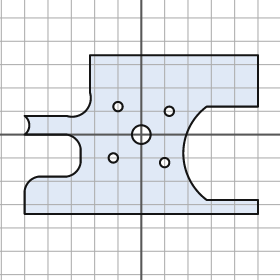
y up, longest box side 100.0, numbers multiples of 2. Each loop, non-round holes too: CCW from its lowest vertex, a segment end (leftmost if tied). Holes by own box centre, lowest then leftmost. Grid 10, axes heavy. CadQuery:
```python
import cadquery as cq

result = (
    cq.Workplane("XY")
    .moveTo(-50.0, -34.0)
    .lineTo(50.0, -34.0)
    .lineTo(50.0, -28.0)
    .lineTo(28.0, -28.0)
    .threePointArc((18.0, -8.0), (28.0, 12.0))
    .lineTo(50.0, 12.0)
    .lineTo(50.0, 34.0)
    .lineTo(-22.0, 34.0)
    .lineTo(-22.0, 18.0)
    .threePointArc((-24.0, 10.0), (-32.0, 8.0))
    .lineTo(-50.0, 8.0)
    .threePointArc((-48.0, 4.0), (-50.0, 0.0))
    .lineTo(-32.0, 0.0)
    .threePointArc((-28.0, -2.0), (-26.0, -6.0))
    .lineTo(-26.0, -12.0)
    .threePointArc((-28.0, -16.0), (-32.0, -18.0))
    .lineTo(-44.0, -18.0)
    .threePointArc((-48.0, -20.0), (-50.0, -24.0))
    .close()
    .moveTo(10.0, -12.0)
    .circle(2.0)
    .moveTo(-12.0, -10.0)
    .circle(2.0)
    .moveTo(0.0, 0.0)
    .circle(4.0)
    .moveTo(12.0, 10.0)
    .circle(2.0)
    .moveTo(-10.0, 12.0)
    .circle(2.0)
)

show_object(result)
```